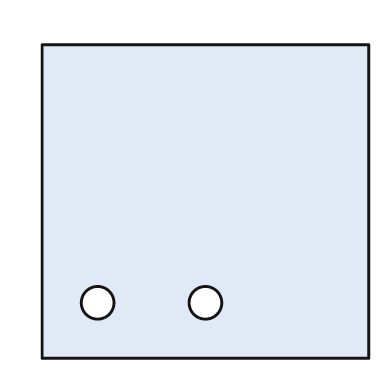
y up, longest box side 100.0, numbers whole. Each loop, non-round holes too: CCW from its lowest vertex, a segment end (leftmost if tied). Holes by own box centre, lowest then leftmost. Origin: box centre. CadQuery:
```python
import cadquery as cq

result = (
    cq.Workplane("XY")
    .moveTo(-50.0, -48.0)
    .lineTo(50.0, -48.0)
    .lineTo(50.0, 48.0)
    .lineTo(-50.0, 48.0)
    .close()
    .moveTo(-33.0, -31.0)
    .circle(5.0)
    .moveTo(0.0, -31.0)
    .circle(5.0)
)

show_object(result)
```